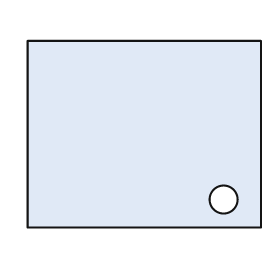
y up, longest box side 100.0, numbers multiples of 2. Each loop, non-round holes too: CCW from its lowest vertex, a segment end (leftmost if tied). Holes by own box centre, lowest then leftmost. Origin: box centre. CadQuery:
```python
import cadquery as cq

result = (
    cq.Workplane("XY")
    .moveTo(-50.0, -40.0)
    .lineTo(50.0, -40.0)
    .lineTo(50.0, 40.0)
    .lineTo(-50.0, 40.0)
    .close()
    .moveTo(34.0, -28.0)
    .circle(6.0)
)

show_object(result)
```